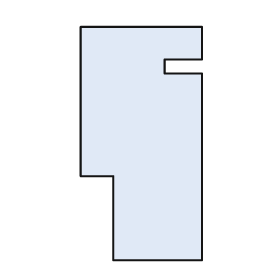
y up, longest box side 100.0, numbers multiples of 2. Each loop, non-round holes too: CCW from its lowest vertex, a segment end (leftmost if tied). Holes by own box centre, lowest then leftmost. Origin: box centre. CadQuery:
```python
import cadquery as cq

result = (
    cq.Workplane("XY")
    .moveTo(-12.0, -50.0)
    .lineTo(26.0, -50.0)
    .lineTo(26.0, 30.0)
    .lineTo(10.0, 30.0)
    .lineTo(10.0, 36.0)
    .lineTo(26.0, 36.0)
    .lineTo(26.0, 50.0)
    .lineTo(-26.0, 50.0)
    .lineTo(-26.0, -14.0)
    .lineTo(-12.0, -14.0)
    .close()
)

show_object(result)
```